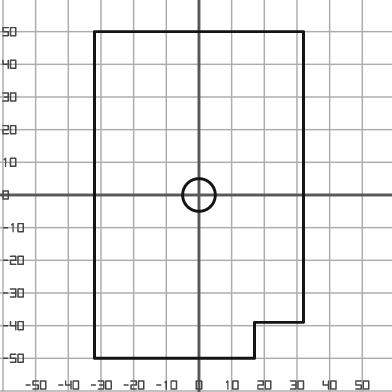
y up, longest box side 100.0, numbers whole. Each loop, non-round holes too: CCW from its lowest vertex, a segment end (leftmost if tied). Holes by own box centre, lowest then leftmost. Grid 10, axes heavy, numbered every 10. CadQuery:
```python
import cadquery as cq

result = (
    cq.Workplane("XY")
    .moveTo(-32.0, -50.0)
    .lineTo(17.0, -50.0)
    .lineTo(17.0, -39.0)
    .lineTo(32.0, -39.0)
    .lineTo(32.0, 50.0)
    .lineTo(-32.0, 50.0)
    .close()
    .moveTo(0.0, 0.0)
    .circle(5.0)
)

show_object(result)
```